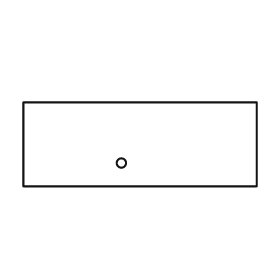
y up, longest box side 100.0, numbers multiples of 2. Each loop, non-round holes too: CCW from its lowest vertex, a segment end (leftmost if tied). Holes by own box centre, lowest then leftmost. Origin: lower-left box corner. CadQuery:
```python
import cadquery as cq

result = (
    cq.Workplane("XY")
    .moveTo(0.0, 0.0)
    .lineTo(100.0, 0.0)
    .lineTo(100.0, 36.0)
    .lineTo(0.0, 36.0)
    .close()
    .moveTo(42.0, 10.0)
    .circle(2.0)
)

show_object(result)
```